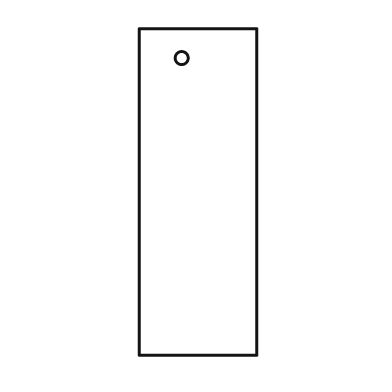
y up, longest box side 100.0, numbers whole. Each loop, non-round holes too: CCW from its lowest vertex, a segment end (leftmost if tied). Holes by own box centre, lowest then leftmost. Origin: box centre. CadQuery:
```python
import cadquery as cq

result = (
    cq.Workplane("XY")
    .moveTo(-18.0, -50.0)
    .lineTo(18.0, -50.0)
    .lineTo(18.0, 50.0)
    .lineTo(-18.0, 50.0)
    .close()
    .moveTo(-5.0, 41.0)
    .circle(2.0)
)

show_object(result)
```